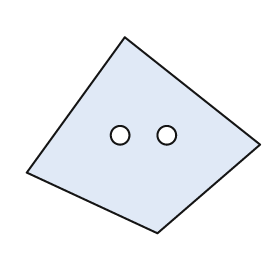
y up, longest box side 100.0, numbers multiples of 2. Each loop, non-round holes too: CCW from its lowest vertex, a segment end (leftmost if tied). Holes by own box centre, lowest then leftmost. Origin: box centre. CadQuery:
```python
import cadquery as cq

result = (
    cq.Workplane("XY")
    .moveTo(6.0, -42.0)
    .lineTo(50.0, -4.0)
    .lineTo(-8.0, 42.0)
    .lineTo(-50.0, -16.0)
    .close()
    .moveTo(-10.0, 0.0)
    .circle(4.0)
    .moveTo(10.0, 0.0)
    .circle(4.0)
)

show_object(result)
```